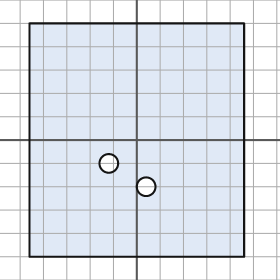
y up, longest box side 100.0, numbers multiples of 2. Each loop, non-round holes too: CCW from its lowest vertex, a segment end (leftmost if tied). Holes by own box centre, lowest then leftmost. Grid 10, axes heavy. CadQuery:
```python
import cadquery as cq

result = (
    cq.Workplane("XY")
    .moveTo(-46.0, -50.0)
    .lineTo(46.0, -50.0)
    .lineTo(46.0, 50.0)
    .lineTo(-46.0, 50.0)
    .close()
    .moveTo(4.0, -20.0)
    .circle(4.0)
    .moveTo(-12.0, -10.0)
    .circle(4.0)
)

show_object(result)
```